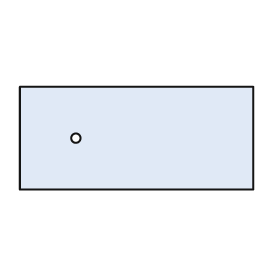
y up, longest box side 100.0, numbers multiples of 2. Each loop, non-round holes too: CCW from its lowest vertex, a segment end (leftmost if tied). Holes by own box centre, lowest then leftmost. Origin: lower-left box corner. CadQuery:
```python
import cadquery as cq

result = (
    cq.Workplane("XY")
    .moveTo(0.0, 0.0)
    .lineTo(100.0, 0.0)
    .lineTo(100.0, 44.0)
    .lineTo(0.0, 44.0)
    .close()
    .moveTo(24.0, 22.0)
    .circle(2.0)
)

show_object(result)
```